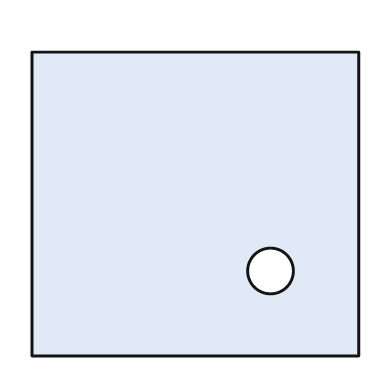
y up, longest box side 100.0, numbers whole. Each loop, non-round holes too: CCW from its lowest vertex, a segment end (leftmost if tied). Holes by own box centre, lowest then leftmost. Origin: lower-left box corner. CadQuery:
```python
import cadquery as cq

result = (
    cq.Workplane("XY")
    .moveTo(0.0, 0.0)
    .lineTo(100.0, 0.0)
    .lineTo(100.0, 93.0)
    .lineTo(0.0, 93.0)
    .close()
    .moveTo(73.0, 26.0)
    .circle(7.0)
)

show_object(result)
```